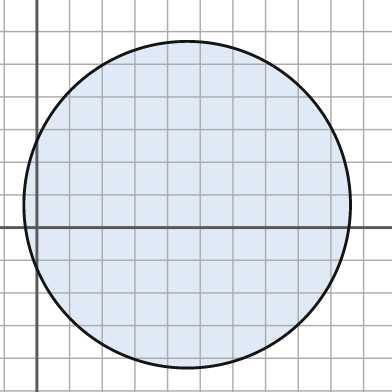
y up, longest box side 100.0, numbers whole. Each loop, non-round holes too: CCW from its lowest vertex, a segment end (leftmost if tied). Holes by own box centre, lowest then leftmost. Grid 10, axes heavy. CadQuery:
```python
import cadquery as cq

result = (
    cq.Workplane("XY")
    .moveTo(46.0, 7.0)
    .circle(50.0)
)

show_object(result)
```